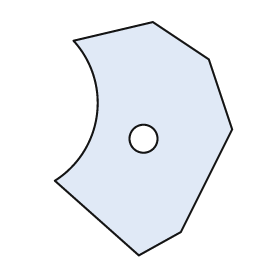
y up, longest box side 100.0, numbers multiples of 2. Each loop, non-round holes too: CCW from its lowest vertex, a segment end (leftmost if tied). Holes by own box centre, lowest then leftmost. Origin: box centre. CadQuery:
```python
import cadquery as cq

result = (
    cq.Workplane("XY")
    .moveTo(-2.0, -50.0)
    .lineTo(16.0, -40.0)
    .lineTo(38.0, 4.0)
    .lineTo(28.0, 34.0)
    .lineTo(4.0, 50.0)
    .lineTo(-30.0, 42.0)
    .threePointArc((-20.0, 10.0), (-38.0, -18.0))
    .close()
    .moveTo(0.0, 0.0)
    .circle(6.0)
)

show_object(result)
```